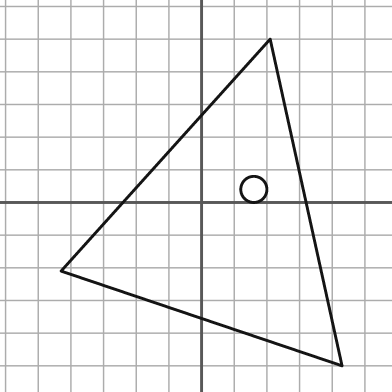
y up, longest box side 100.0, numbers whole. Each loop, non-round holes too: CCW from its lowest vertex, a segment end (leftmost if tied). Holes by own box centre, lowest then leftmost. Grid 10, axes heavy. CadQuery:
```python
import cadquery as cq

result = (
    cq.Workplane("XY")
    .moveTo(43.0, -50.0)
    .lineTo(21.0, 50.0)
    .lineTo(-43.0, -21.0)
    .close()
    .moveTo(16.0, 4.0)
    .circle(4.0)
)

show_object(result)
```